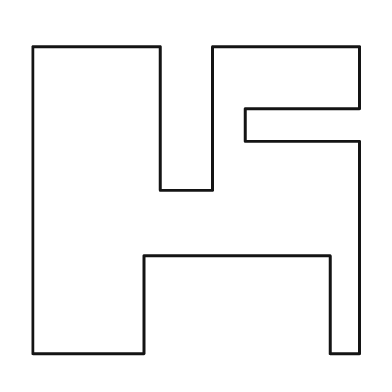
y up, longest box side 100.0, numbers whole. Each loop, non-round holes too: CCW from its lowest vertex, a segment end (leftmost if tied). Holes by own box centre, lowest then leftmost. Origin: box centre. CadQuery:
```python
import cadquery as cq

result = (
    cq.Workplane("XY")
    .moveTo(-50.0, -47.0)
    .lineTo(-16.0, -47.0)
    .lineTo(-16.0, -17.0)
    .lineTo(41.0, -17.0)
    .lineTo(41.0, -47.0)
    .lineTo(50.0, -47.0)
    .lineTo(50.0, 18.0)
    .lineTo(15.0, 18.0)
    .lineTo(15.0, 28.0)
    .lineTo(50.0, 28.0)
    .lineTo(50.0, 47.0)
    .lineTo(5.0, 47.0)
    .lineTo(5.0, 3.0)
    .lineTo(-11.0, 3.0)
    .lineTo(-11.0, 47.0)
    .lineTo(-50.0, 47.0)
    .close()
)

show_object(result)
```